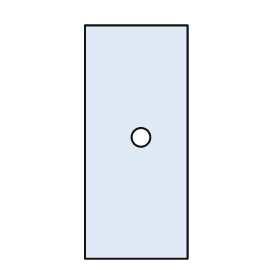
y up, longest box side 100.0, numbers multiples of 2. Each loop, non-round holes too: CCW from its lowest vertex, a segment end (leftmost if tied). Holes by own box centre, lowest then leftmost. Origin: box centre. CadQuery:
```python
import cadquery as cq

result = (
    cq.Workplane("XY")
    .moveTo(-22.0, -50.0)
    .lineTo(22.0, -50.0)
    .lineTo(22.0, 50.0)
    .lineTo(-22.0, 50.0)
    .close()
    .moveTo(2.0, 2.0)
    .circle(4.0)
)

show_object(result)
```